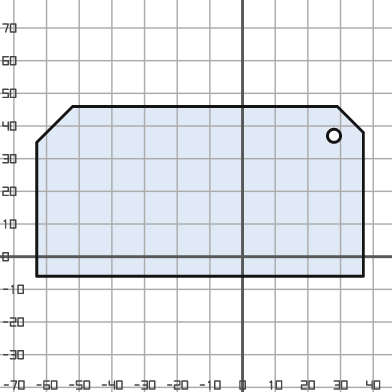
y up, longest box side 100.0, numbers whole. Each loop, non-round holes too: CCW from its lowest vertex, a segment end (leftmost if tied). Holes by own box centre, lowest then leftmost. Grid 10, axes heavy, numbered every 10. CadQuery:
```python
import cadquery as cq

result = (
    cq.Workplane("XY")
    .moveTo(-63.0, -6.0)
    .lineTo(37.0, -6.0)
    .lineTo(37.0, 38.0)
    .lineTo(29.0, 46.0)
    .lineTo(-52.0, 46.0)
    .lineTo(-63.0, 35.0)
    .close()
    .moveTo(28.0, 37.0)
    .circle(2.0)
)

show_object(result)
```